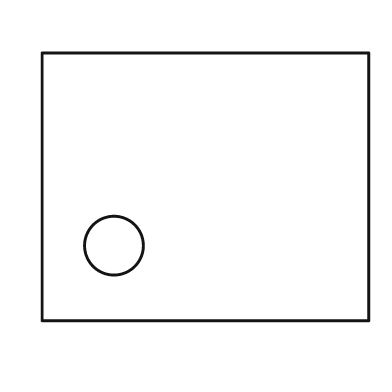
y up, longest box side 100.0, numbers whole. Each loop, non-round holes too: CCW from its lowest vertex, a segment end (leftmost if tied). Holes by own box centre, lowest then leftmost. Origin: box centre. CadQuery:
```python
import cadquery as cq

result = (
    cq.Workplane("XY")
    .moveTo(-50.0, -41.0)
    .lineTo(50.0, -41.0)
    .lineTo(50.0, 41.0)
    .lineTo(-50.0, 41.0)
    .close()
    .moveTo(-28.0, -18.0)
    .circle(9.0)
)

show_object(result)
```